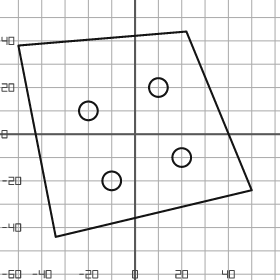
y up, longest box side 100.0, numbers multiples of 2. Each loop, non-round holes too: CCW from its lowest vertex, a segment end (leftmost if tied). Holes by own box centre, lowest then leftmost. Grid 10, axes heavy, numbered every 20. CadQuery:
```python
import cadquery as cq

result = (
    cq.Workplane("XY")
    .moveTo(-34.0, -44.0)
    .lineTo(50.0, -24.0)
    .lineTo(22.0, 44.0)
    .lineTo(-50.0, 38.0)
    .close()
    .moveTo(-10.0, -20.0)
    .circle(4.0)
    .moveTo(20.0, -10.0)
    .circle(4.0)
    .moveTo(-20.0, 10.0)
    .circle(4.0)
    .moveTo(10.0, 20.0)
    .circle(4.0)
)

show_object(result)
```